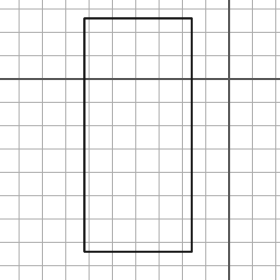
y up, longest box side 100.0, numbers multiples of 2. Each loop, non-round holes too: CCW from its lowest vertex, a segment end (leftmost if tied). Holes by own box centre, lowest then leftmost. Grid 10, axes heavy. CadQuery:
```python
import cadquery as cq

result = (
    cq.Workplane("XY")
    .moveTo(-62.0, -74.0)
    .lineTo(-16.0, -74.0)
    .lineTo(-16.0, 26.0)
    .lineTo(-62.0, 26.0)
    .close()
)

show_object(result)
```